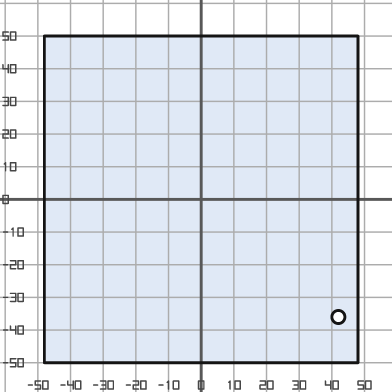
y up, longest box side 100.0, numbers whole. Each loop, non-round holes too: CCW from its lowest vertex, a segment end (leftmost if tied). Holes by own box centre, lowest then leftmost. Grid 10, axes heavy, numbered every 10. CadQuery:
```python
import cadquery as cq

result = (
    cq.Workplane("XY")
    .moveTo(-48.0, -50.0)
    .lineTo(48.0, -50.0)
    .lineTo(48.0, 50.0)
    .lineTo(-48.0, 50.0)
    .close()
    .moveTo(42.0, -36.0)
    .circle(2.0)
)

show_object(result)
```